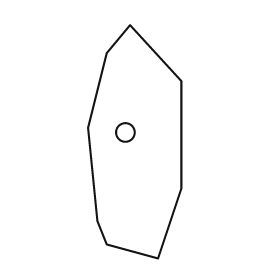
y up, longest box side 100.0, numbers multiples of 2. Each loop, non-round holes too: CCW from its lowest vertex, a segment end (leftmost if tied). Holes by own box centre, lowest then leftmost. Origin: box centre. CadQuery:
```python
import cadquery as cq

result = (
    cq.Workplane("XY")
    .moveTo(10.0, -50.0)
    .lineTo(20.0, -20.0)
    .lineTo(20.0, 26.0)
    .lineTo(-2.0, 50.0)
    .lineTo(-12.0, 38.0)
    .lineTo(-20.0, 6.0)
    .lineTo(-16.0, -34.0)
    .lineTo(-12.0, -44.0)
    .close()
    .moveTo(-4.0, 4.0)
    .circle(4.0)
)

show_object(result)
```